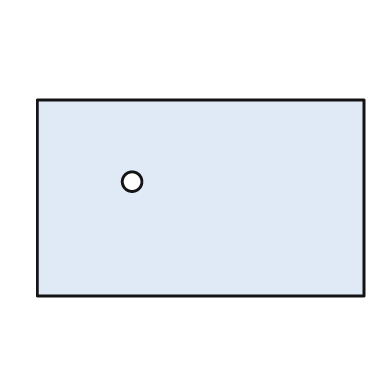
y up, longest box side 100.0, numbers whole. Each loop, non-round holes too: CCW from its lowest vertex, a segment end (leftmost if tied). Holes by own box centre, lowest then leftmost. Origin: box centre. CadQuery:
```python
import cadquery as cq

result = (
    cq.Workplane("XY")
    .moveTo(-50.0, -30.0)
    .lineTo(50.0, -30.0)
    .lineTo(50.0, 30.0)
    .lineTo(-50.0, 30.0)
    .close()
    .moveTo(-21.0, 5.0)
    .circle(3.0)
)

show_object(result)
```